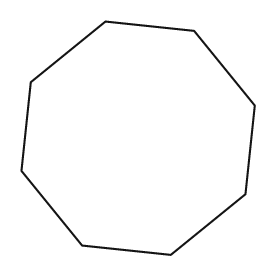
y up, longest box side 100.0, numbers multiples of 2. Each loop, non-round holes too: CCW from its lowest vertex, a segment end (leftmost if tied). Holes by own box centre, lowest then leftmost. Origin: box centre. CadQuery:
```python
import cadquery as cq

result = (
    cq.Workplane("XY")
    .moveTo(14.0, -50.0)
    .lineTo(46.0, -24.0)
    .lineTo(50.0, 14.0)
    .lineTo(24.0, 46.0)
    .lineTo(-14.0, 50.0)
    .lineTo(-46.0, 24.0)
    .lineTo(-50.0, -14.0)
    .lineTo(-24.0, -46.0)
    .close()
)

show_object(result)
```